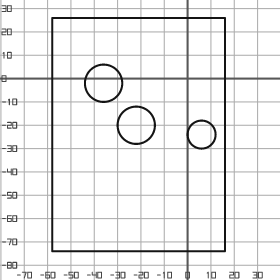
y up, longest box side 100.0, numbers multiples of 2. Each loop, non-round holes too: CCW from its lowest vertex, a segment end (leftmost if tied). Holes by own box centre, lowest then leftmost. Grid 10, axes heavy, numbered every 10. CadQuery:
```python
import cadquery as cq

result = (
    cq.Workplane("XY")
    .moveTo(-58.0, -74.0)
    .lineTo(16.0, -74.0)
    .lineTo(16.0, 26.0)
    .lineTo(-58.0, 26.0)
    .close()
    .moveTo(6.0, -24.0)
    .circle(6.0)
    .moveTo(-22.0, -20.0)
    .circle(8.0)
    .moveTo(-36.0, -2.0)
    .circle(8.0)
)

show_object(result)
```